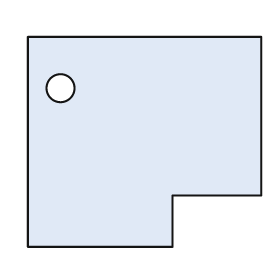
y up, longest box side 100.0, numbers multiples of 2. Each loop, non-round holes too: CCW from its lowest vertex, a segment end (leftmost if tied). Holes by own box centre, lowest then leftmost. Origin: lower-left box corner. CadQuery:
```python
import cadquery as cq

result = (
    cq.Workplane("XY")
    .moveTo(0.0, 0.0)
    .lineTo(62.0, 0.0)
    .lineTo(62.0, 22.0)
    .lineTo(100.0, 22.0)
    .lineTo(100.0, 90.0)
    .lineTo(0.0, 90.0)
    .close()
    .moveTo(14.0, 68.0)
    .circle(6.0)
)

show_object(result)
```